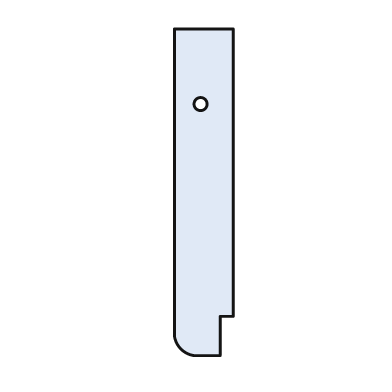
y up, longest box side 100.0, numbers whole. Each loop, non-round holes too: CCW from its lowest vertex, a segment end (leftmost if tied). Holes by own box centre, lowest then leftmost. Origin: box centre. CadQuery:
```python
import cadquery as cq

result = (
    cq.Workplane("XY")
    .moveTo(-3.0, -50.0)
    .lineTo(5.0, -50.0)
    .lineTo(5.0, -38.0)
    .lineTo(9.0, -38.0)
    .lineTo(9.0, 50.0)
    .lineTo(-9.0, 50.0)
    .lineTo(-9.0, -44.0)
    .threePointArc((-7.0, -48.0), (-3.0, -50.0))
    .close()
    .moveTo(-1.0, 27.0)
    .circle(2.0)
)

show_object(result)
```